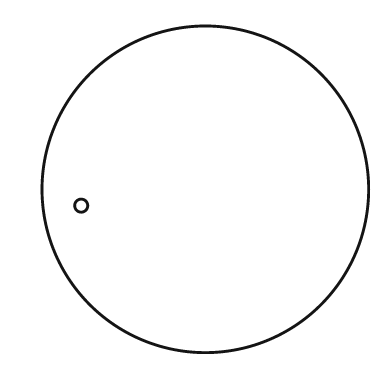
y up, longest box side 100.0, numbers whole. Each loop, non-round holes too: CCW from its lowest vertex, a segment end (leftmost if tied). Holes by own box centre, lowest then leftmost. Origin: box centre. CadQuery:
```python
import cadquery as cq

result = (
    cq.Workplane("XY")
    .moveTo(0.0, 0.0)
    .circle(50.0)
    .moveTo(-38.0, -5.0)
    .circle(2.0)
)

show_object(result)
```